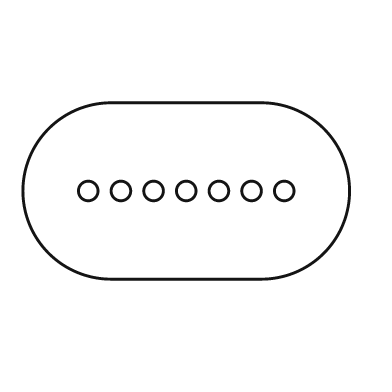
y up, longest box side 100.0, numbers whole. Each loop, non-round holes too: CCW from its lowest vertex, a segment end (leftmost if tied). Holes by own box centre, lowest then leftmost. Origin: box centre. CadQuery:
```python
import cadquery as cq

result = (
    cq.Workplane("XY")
    .moveTo(-23.0, -27.0)
    .lineTo(23.0, -27.0)
    .threePointArc((50.0, 0.0), (23.0, 27.0))
    .lineTo(-23.0, 27.0)
    .threePointArc((-50.0, 0.0), (-23.0, -27.0))
    .close()
    .moveTo(-30.0, 0.0)
    .circle(3.0)
    .moveTo(-20.0, 0.0)
    .circle(3.0)
    .moveTo(-10.0, 0.0)
    .circle(3.0)
    .moveTo(0.0, 0.0)
    .circle(3.0)
    .moveTo(10.0, 0.0)
    .circle(3.0)
    .moveTo(20.0, 0.0)
    .circle(3.0)
    .moveTo(30.0, 0.0)
    .circle(3.0)
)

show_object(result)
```